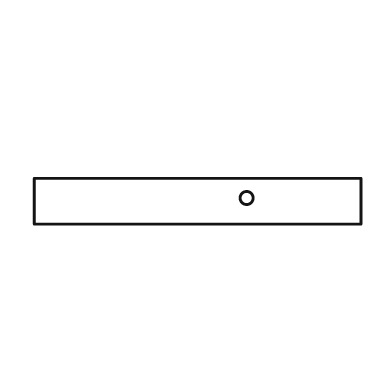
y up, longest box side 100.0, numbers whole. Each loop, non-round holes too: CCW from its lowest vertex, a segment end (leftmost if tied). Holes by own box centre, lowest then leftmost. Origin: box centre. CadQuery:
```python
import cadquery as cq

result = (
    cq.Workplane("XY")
    .moveTo(-50.0, -7.0)
    .lineTo(50.0, -7.0)
    .lineTo(50.0, 7.0)
    .lineTo(-50.0, 7.0)
    .close()
    .moveTo(15.0, 1.0)
    .circle(2.0)
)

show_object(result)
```